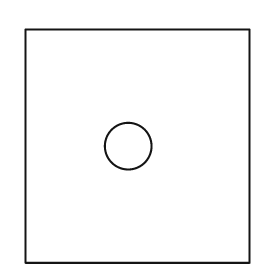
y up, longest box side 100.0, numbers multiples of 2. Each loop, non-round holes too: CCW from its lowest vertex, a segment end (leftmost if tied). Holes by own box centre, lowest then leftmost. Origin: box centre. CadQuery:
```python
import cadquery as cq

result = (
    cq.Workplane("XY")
    .moveTo(-48.0, -50.0)
    .lineTo(48.0, -50.0)
    .lineTo(48.0, 50.0)
    .lineTo(-48.0, 50.0)
    .close()
    .moveTo(-4.0, 0.0)
    .circle(10.0)
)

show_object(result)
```